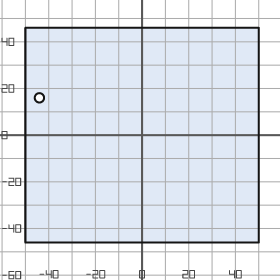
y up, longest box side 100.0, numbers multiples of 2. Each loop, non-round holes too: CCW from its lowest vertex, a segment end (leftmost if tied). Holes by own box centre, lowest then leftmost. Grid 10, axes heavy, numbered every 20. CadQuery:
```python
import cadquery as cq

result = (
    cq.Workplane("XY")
    .moveTo(-50.0, -46.0)
    .lineTo(50.0, -46.0)
    .lineTo(50.0, 46.0)
    .lineTo(-50.0, 46.0)
    .close()
    .moveTo(-44.0, 16.0)
    .circle(2.0)
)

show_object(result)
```